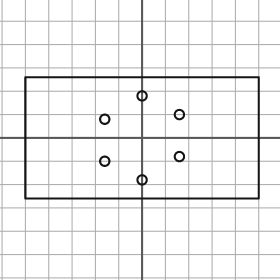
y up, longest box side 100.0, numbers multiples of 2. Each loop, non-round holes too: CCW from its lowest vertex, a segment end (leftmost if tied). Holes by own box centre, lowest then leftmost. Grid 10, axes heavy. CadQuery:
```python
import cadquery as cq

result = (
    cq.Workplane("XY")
    .moveTo(-50.0, -26.0)
    .lineTo(50.0, -26.0)
    .lineTo(50.0, 26.0)
    .lineTo(-50.0, 26.0)
    .close()
    .moveTo(0.0, -18.0)
    .circle(2.0)
    .moveTo(-16.0, -10.0)
    .circle(2.0)
    .moveTo(16.0, -8.0)
    .circle(2.0)
    .moveTo(-16.0, 8.0)
    .circle(2.0)
    .moveTo(16.0, 10.0)
    .circle(2.0)
    .moveTo(0.0, 18.0)
    .circle(2.0)
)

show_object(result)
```